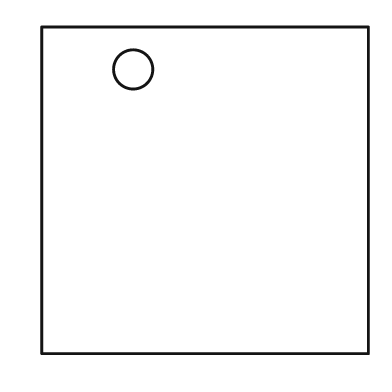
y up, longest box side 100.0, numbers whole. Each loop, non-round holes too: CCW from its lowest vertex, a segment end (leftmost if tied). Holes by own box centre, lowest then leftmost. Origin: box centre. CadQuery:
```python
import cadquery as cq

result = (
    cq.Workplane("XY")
    .moveTo(-50.0, -50.0)
    .lineTo(50.0, -50.0)
    .lineTo(50.0, 50.0)
    .lineTo(-50.0, 50.0)
    .close()
    .moveTo(-22.0, 37.0)
    .circle(6.0)
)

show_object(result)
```